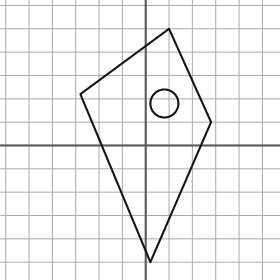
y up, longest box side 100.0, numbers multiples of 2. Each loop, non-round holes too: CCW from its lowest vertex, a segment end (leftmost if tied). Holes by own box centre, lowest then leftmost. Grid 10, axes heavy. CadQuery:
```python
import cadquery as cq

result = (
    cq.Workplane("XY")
    .moveTo(2.0, -50.0)
    .lineTo(28.0, 10.0)
    .lineTo(10.0, 50.0)
    .lineTo(-28.0, 22.0)
    .close()
    .moveTo(8.0, 18.0)
    .circle(6.0)
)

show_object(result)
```